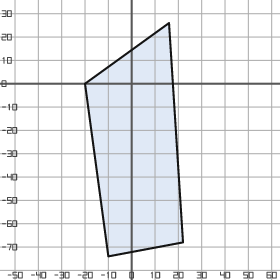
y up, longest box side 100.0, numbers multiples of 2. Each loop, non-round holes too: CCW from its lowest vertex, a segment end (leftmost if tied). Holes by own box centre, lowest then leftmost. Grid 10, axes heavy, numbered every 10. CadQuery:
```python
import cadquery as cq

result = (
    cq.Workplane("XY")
    .moveTo(-10.0, -74.0)
    .lineTo(22.0, -68.0)
    .lineTo(16.0, 26.0)
    .lineTo(-20.0, 0.0)
    .close()
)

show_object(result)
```